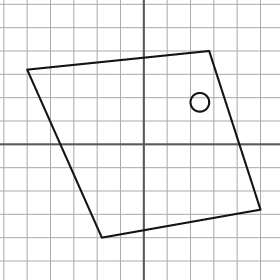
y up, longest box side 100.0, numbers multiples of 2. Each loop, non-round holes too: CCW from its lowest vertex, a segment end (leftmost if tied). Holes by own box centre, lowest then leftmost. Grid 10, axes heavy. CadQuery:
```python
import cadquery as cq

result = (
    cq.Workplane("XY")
    .moveTo(-18.0, -40.0)
    .lineTo(50.0, -28.0)
    .lineTo(28.0, 40.0)
    .lineTo(-50.0, 32.0)
    .close()
    .moveTo(24.0, 18.0)
    .circle(4.0)
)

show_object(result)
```